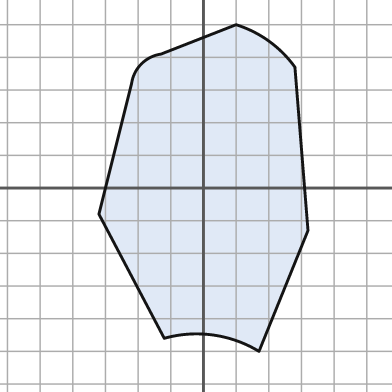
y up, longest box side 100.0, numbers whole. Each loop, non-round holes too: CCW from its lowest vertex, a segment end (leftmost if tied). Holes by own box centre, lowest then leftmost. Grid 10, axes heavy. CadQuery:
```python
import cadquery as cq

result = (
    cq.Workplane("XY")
    .moveTo(17.0, -50.0)
    .lineTo(32.0, -13.0)
    .lineTo(28.0, 37.0)
    .threePointArc((20.0, 45.0), (10.0, 50.0))
    .lineTo(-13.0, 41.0)
    .threePointArc((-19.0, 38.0), (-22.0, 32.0))
    .lineTo(-32.0, -8.0)
    .lineTo(-12.0, -46.0)
    .threePointArc((3.0, -45.0), (17.0, -50.0))
    .close()
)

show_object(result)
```